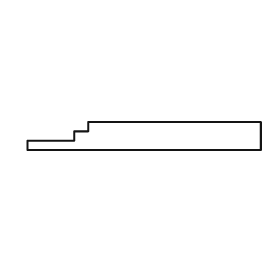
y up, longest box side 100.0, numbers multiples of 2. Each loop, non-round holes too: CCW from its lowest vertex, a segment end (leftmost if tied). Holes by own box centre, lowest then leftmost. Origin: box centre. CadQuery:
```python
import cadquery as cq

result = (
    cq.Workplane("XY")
    .moveTo(-50.0, -6.0)
    .lineTo(50.0, -6.0)
    .lineTo(50.0, 6.0)
    .lineTo(-24.0, 6.0)
    .lineTo(-24.0, 2.0)
    .lineTo(-30.0, 2.0)
    .lineTo(-30.0, -2.0)
    .lineTo(-50.0, -2.0)
    .close()
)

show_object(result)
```